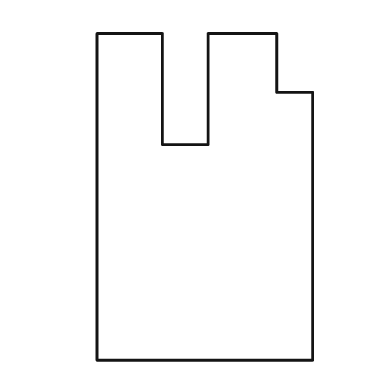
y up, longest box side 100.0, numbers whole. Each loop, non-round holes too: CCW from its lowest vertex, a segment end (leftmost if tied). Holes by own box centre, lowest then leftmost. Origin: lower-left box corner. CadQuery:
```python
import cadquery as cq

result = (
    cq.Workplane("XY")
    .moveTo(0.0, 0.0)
    .lineTo(66.0, 0.0)
    .lineTo(66.0, 82.0)
    .lineTo(55.0, 82.0)
    .lineTo(55.0, 100.0)
    .lineTo(34.0, 100.0)
    .lineTo(34.0, 66.0)
    .lineTo(20.0, 66.0)
    .lineTo(20.0, 100.0)
    .lineTo(0.0, 100.0)
    .close()
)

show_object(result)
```